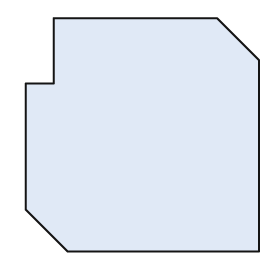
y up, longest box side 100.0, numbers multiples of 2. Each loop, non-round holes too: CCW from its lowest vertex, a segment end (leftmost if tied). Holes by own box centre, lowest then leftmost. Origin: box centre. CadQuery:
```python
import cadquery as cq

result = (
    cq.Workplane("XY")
    .moveTo(-32.0, -50.0)
    .lineTo(50.0, -50.0)
    .lineTo(50.0, 32.0)
    .lineTo(32.0, 50.0)
    .lineTo(-38.0, 50.0)
    .lineTo(-38.0, 22.0)
    .lineTo(-50.0, 22.0)
    .lineTo(-50.0, -32.0)
    .close()
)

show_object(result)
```